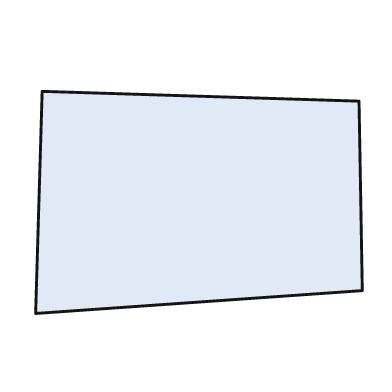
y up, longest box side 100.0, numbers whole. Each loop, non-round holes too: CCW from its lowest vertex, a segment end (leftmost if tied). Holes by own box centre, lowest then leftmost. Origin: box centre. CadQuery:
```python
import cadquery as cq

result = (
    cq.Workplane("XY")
    .moveTo(-50.0, -34.0)
    .lineTo(50.0, -27.0)
    .lineTo(49.0, 31.0)
    .lineTo(-48.0, 34.0)
    .close()
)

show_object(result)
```